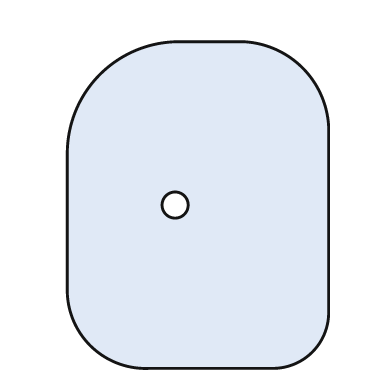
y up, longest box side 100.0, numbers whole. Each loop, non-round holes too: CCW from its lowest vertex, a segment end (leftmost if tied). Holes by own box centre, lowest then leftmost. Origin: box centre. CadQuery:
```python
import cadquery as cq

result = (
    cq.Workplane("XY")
    .moveTo(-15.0, -50.0)
    .lineTo(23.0, -50.0)
    .threePointArc((35.0, -45.0), (40.0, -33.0))
    .lineTo(40.0, 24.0)
    .threePointArc((32.0, 42.0), (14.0, 50.0))
    .lineTo(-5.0, 50.0)
    .threePointArc((-30.0, 40.0), (-40.0, 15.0))
    .lineTo(-40.0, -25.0)
    .threePointArc((-33.0, -43.0), (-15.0, -50.0))
    .close()
    .moveTo(-7.0, 0.0)
    .circle(4.0)
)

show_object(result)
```